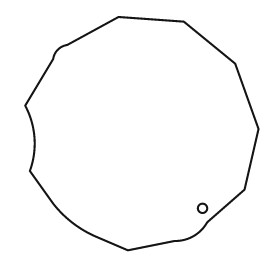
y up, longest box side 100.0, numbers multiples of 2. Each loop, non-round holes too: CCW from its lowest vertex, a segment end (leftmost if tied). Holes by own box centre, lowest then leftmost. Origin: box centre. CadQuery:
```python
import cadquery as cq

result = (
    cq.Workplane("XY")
    .moveTo(-6.0, -50.0)
    .lineTo(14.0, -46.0)
    .threePointArc((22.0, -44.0), (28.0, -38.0))
    .lineTo(44.0, -24.0)
    .lineTo(50.0, 2.0)
    .lineTo(40.0, 30.0)
    .lineTo(18.0, 48.0)
    .lineTo(-10.0, 50.0)
    .lineTo(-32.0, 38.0)
    .threePointArc((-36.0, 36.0), (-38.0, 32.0))
    .lineTo(-50.0, 12.0)
    .threePointArc((-46.0, -2.0), (-48.0, -16.0))
    .lineTo(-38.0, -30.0)
    .threePointArc((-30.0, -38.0), (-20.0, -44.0))
    .close()
    .moveTo(26.0, -32.0)
    .circle(2.0)
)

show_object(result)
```